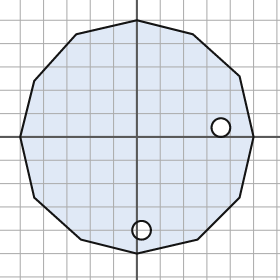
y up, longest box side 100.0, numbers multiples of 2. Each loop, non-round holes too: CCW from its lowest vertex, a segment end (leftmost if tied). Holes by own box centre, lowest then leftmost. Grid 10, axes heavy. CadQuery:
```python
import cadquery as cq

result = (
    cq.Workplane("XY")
    .moveTo(0.0, -50.0)
    .lineTo(26.0, -44.0)
    .lineTo(44.0, -26.0)
    .lineTo(50.0, 0.0)
    .lineTo(44.0, 26.0)
    .lineTo(24.0, 44.0)
    .lineTo(0.0, 50.0)
    .lineTo(-26.0, 44.0)
    .lineTo(-44.0, 24.0)
    .lineTo(-50.0, 0.0)
    .lineTo(-44.0, -26.0)
    .lineTo(-24.0, -44.0)
    .close()
    .moveTo(2.0, -40.0)
    .circle(4.0)
    .moveTo(36.0, 4.0)
    .circle(4.0)
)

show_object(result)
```